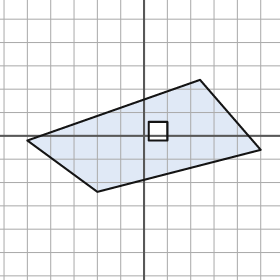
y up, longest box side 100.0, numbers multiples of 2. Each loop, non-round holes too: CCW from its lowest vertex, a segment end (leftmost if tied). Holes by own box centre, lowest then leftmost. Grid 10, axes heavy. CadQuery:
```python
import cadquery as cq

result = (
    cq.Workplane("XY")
    .moveTo(-20.0, -24.0)
    .lineTo(50.0, -6.0)
    .lineTo(24.0, 24.0)
    .lineTo(-50.0, -2.0)
    .close()
    .moveTo(2.0, -2.0)
    .lineTo(10.0, -2.0)
    .lineTo(10.0, 6.0)
    .lineTo(2.0, 6.0)
    .close()
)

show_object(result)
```